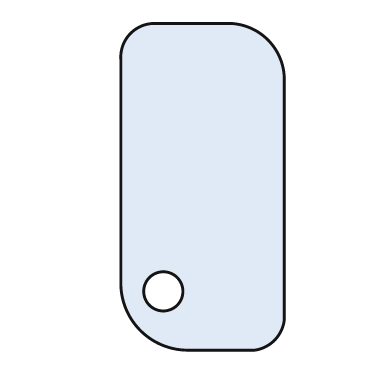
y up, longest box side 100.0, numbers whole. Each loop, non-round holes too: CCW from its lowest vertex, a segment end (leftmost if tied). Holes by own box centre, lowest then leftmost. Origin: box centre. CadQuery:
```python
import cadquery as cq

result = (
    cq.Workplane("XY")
    .moveTo(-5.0, -50.0)
    .lineTo(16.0, -50.0)
    .threePointArc((22.0, -47.0), (25.0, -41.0))
    .lineTo(25.0, 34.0)
    .threePointArc((20.0, 45.0), (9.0, 50.0))
    .lineTo(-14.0, 50.0)
    .threePointArc((-22.0, 47.0), (-25.0, 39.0))
    .lineTo(-25.0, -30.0)
    .threePointArc((-19.0, -44.0), (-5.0, -50.0))
    .close()
    .moveTo(-12.0, -32.0)
    .circle(6.0)
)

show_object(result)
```